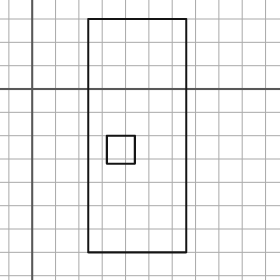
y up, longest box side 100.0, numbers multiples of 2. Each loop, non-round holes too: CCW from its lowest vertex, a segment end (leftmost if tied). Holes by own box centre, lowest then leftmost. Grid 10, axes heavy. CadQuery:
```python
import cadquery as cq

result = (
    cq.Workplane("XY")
    .moveTo(24.0, -70.0)
    .lineTo(66.0, -70.0)
    .lineTo(66.0, 30.0)
    .lineTo(24.0, 30.0)
    .close()
    .moveTo(32.0, -32.0)
    .lineTo(44.0, -32.0)
    .lineTo(44.0, -20.0)
    .lineTo(32.0, -20.0)
    .close()
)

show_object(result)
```